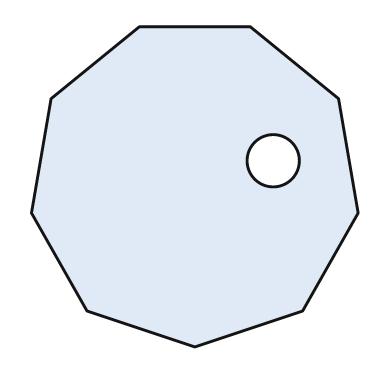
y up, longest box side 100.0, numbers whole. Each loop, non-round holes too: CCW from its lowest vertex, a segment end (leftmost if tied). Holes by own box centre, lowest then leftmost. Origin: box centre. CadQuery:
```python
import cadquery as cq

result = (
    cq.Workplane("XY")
    .moveTo(0.0, -49.0)
    .lineTo(33.0, -38.0)
    .lineTo(50.0, -8.0)
    .lineTo(44.0, 27.0)
    .lineTo(17.0, 49.0)
    .lineTo(-17.0, 49.0)
    .lineTo(-44.0, 27.0)
    .lineTo(-50.0, -8.0)
    .lineTo(-33.0, -38.0)
    .close()
    .moveTo(24.0, 8.0)
    .circle(8.0)
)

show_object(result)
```